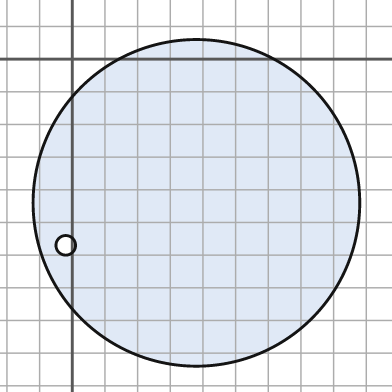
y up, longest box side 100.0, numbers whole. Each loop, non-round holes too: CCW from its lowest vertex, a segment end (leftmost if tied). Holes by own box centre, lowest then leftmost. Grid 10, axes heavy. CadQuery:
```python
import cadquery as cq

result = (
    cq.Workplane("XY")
    .moveTo(38.0, -44.0)
    .circle(50.0)
    .moveTo(-2.0, -57.0)
    .circle(3.0)
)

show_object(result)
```